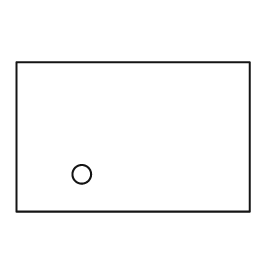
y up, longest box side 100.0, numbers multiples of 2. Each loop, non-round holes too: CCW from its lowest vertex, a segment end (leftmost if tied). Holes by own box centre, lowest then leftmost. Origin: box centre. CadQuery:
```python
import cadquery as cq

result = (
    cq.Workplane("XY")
    .moveTo(-50.0, -32.0)
    .lineTo(50.0, -32.0)
    .lineTo(50.0, 32.0)
    .lineTo(-50.0, 32.0)
    .close()
    .moveTo(-22.0, -16.0)
    .circle(4.0)
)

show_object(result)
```